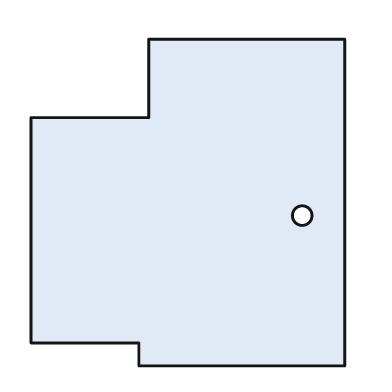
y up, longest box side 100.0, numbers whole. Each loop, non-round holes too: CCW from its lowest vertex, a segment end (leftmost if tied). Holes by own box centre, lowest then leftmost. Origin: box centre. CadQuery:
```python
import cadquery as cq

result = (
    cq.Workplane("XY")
    .moveTo(-15.0, -50.0)
    .lineTo(48.0, -50.0)
    .lineTo(48.0, 50.0)
    .lineTo(-12.0, 50.0)
    .lineTo(-12.0, 26.0)
    .lineTo(-48.0, 26.0)
    .lineTo(-48.0, -43.0)
    .lineTo(-15.0, -43.0)
    .close()
    .moveTo(35.0, -4.0)
    .circle(3.0)
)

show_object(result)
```